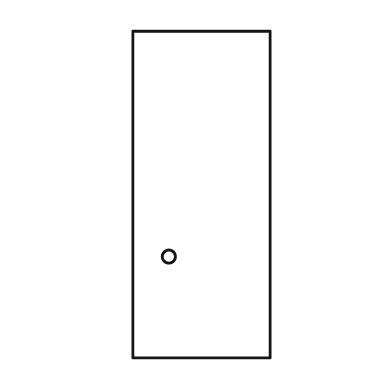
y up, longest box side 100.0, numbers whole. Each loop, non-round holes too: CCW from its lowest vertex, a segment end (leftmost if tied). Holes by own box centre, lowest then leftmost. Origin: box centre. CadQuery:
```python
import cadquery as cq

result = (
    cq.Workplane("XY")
    .moveTo(-21.0, -50.0)
    .lineTo(21.0, -50.0)
    .lineTo(21.0, 50.0)
    .lineTo(-21.0, 50.0)
    .close()
    .moveTo(-10.0, -19.0)
    .circle(2.0)
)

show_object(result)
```